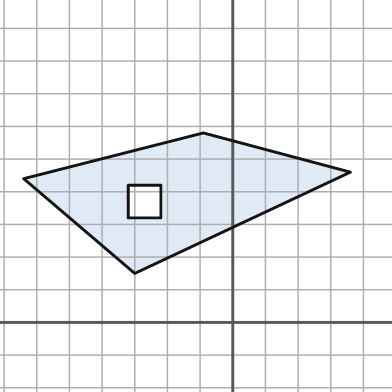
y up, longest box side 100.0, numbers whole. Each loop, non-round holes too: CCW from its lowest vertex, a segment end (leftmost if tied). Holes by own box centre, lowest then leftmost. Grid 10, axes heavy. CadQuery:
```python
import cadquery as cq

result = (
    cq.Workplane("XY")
    .moveTo(-30.0, 15.0)
    .lineTo(36.0, 46.0)
    .lineTo(-9.0, 58.0)
    .lineTo(-64.0, 44.0)
    .close()
    .moveTo(-32.0, 32.0)
    .lineTo(-22.0, 32.0)
    .lineTo(-22.0, 42.0)
    .lineTo(-32.0, 42.0)
    .close()
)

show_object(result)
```